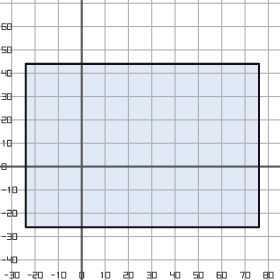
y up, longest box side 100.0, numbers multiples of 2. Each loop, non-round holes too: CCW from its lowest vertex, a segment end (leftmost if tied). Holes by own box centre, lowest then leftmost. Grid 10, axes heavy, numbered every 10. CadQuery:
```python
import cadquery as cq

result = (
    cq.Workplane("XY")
    .moveTo(-24.0, -26.0)
    .lineTo(76.0, -26.0)
    .lineTo(76.0, 44.0)
    .lineTo(-24.0, 44.0)
    .close()
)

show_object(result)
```